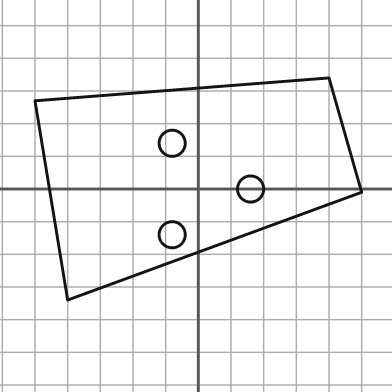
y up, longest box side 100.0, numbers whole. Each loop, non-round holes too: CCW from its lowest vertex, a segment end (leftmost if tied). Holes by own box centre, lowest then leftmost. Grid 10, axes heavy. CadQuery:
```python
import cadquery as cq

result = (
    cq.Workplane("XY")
    .moveTo(-40.0, -34.0)
    .lineTo(50.0, -1.0)
    .lineTo(40.0, 34.0)
    .lineTo(-50.0, 27.0)
    .close()
    .moveTo(-8.0, -14.0)
    .circle(4.0)
    .moveTo(16.0, 0.0)
    .circle(4.0)
    .moveTo(-8.0, 14.0)
    .circle(4.0)
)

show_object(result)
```